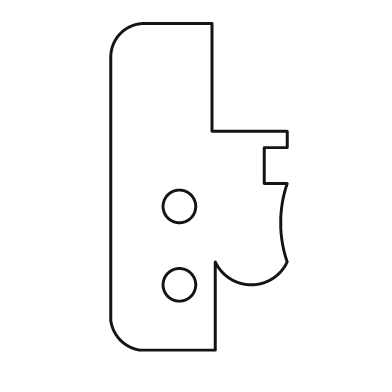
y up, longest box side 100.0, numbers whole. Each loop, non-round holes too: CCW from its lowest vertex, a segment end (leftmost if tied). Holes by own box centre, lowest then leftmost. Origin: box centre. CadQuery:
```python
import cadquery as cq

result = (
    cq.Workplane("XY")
    .moveTo(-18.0, -50.0)
    .lineTo(5.0, -50.0)
    .lineTo(5.0, -23.0)
    .threePointArc((16.0, -30.0), (27.0, -23.0))
    .threePointArc((25.0, -11.0), (27.0, 1.0))
    .lineTo(20.0, 1.0)
    .lineTo(20.0, 12.0)
    .lineTo(27.0, 12.0)
    .lineTo(27.0, 17.0)
    .lineTo(4.0, 17.0)
    .lineTo(4.0, 50.0)
    .lineTo(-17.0, 50.0)
    .threePointArc((-24.0, 47.0), (-27.0, 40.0))
    .lineTo(-27.0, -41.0)
    .threePointArc((-24.0, -47.0), (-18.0, -50.0))
    .close()
    .moveTo(-6.0, -30.0)
    .circle(5.0)
    .moveTo(-6.0, -6.0)
    .circle(5.0)
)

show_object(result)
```